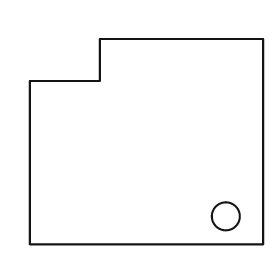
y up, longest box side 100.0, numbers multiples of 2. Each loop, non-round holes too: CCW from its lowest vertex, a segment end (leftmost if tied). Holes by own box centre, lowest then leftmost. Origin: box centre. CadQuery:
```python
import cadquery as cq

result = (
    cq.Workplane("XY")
    .moveTo(-50.0, -44.0)
    .lineTo(50.0, -44.0)
    .lineTo(50.0, 44.0)
    .lineTo(-20.0, 44.0)
    .lineTo(-20.0, 26.0)
    .lineTo(-50.0, 26.0)
    .close()
    .moveTo(34.0, -32.0)
    .circle(6.0)
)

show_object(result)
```